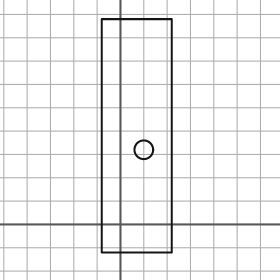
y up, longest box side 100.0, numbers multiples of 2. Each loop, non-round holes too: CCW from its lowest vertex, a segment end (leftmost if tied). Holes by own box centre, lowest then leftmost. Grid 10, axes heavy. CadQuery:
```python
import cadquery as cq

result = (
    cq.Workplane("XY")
    .moveTo(-8.0, -12.0)
    .lineTo(22.0, -12.0)
    .lineTo(22.0, 88.0)
    .lineTo(-8.0, 88.0)
    .close()
    .moveTo(10.0, 32.0)
    .circle(4.0)
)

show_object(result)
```